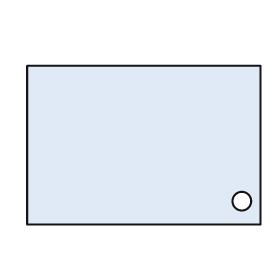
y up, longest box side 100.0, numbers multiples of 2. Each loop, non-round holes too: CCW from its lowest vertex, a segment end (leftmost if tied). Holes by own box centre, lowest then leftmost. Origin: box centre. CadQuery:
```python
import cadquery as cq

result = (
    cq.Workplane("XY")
    .moveTo(-50.0, -34.0)
    .lineTo(50.0, -34.0)
    .lineTo(50.0, 34.0)
    .lineTo(-50.0, 34.0)
    .close()
    .moveTo(42.0, -24.0)
    .circle(4.0)
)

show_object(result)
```